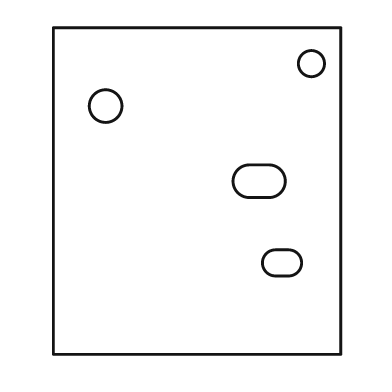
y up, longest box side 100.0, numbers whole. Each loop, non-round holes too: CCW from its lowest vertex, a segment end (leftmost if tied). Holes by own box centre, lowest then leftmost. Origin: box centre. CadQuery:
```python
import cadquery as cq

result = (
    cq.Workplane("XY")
    .moveTo(-44.0, -50.0)
    .lineTo(44.0, -50.0)
    .lineTo(44.0, 50.0)
    .lineTo(-44.0, 50.0)
    .close()
    .moveTo(24.0, -26.0)
    .lineTo(28.0, -26.0)
    .threePointArc((32.0, -22.0), (28.0, -18.0))
    .lineTo(24.0, -18.0)
    .threePointArc((20.0, -22.0), (24.0, -26.0))
    .close()
    .moveTo(16.0, -2.0)
    .lineTo(22.0, -2.0)
    .threePointArc((27.0, 3.0), (22.0, 8.0))
    .lineTo(16.0, 8.0)
    .threePointArc((11.0, 3.0), (16.0, -2.0))
    .close()
    .moveTo(-28.0, 26.0)
    .circle(5.0)
    .moveTo(35.0, 39.0)
    .circle(4.0)
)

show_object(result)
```